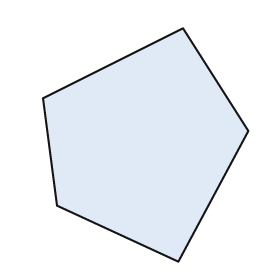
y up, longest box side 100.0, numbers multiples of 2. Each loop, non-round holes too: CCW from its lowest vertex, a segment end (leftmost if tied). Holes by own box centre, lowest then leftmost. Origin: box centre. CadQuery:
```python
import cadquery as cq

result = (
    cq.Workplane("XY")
    .moveTo(14.0, -50.0)
    .lineTo(44.0, 6.0)
    .lineTo(16.0, 50.0)
    .lineTo(-44.0, 20.0)
    .lineTo(-38.0, -26.0)
    .close()
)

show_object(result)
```